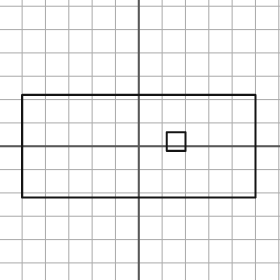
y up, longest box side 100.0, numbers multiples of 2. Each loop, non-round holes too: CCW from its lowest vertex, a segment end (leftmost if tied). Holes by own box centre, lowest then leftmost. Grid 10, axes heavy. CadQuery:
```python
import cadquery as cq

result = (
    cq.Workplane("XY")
    .moveTo(-50.0, -22.0)
    .lineTo(50.0, -22.0)
    .lineTo(50.0, 22.0)
    .lineTo(-50.0, 22.0)
    .close()
    .moveTo(12.0, -2.0)
    .lineTo(20.0, -2.0)
    .lineTo(20.0, 6.0)
    .lineTo(12.0, 6.0)
    .close()
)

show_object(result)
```